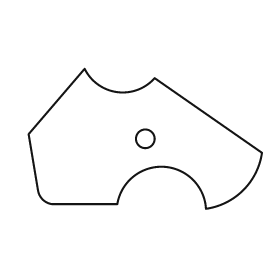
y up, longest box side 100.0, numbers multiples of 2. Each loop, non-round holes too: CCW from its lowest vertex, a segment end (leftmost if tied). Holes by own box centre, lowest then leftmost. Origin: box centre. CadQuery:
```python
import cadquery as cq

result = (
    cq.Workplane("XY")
    .moveTo(26.0, -30.0)
    .threePointArc((42.0, -22.0), (50.0, -6.0))
    .lineTo(4.0, 26.0)
    .threePointArc((-12.0, 20.0), (-26.0, 30.0))
    .lineTo(-50.0, 2.0)
    .lineTo(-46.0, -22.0)
    .threePointArc((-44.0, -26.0), (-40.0, -28.0))
    .lineTo(-12.0, -28.0)
    .threePointArc((8.0, -12.0), (26.0, -30.0))
    .close()
    .moveTo(0.0, 0.0)
    .circle(4.0)
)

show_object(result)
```